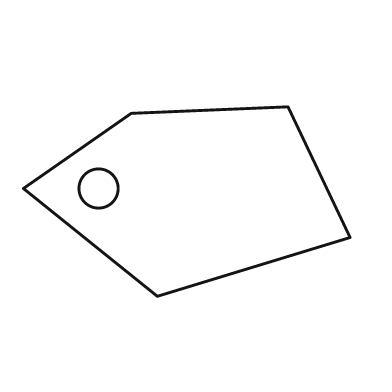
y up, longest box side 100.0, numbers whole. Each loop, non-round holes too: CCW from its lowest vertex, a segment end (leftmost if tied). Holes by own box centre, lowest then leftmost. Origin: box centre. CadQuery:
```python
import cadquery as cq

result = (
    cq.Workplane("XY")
    .moveTo(-9.0, -29.0)
    .lineTo(50.0, -11.0)
    .lineTo(31.0, 29.0)
    .lineTo(-17.0, 27.0)
    .lineTo(-50.0, 4.0)
    .close()
    .moveTo(-27.0, 4.0)
    .circle(6.0)
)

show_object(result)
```